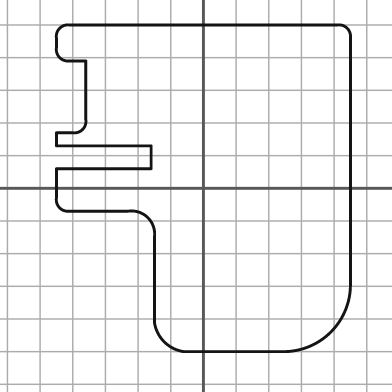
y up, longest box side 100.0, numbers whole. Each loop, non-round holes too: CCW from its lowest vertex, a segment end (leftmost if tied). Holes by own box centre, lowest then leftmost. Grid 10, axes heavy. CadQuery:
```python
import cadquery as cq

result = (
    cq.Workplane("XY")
    .moveTo(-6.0, -50.0)
    .lineTo(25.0, -50.0)
    .threePointArc((39.0, -44.0), (45.0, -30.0))
    .lineTo(45.0, 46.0)
    .threePointArc((44.0, 49.0), (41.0, 50.0))
    .lineTo(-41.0, 50.0)
    .threePointArc((-44.0, 49.0), (-45.0, 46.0))
    .lineTo(-45.0, 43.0)
    .threePointArc((-44.0, 40.0), (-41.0, 39.0))
    .lineTo(-36.0, 39.0)
    .lineTo(-36.0, 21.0)
    .threePointArc((-37.0, 18.0), (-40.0, 17.0))
    .lineTo(-45.0, 17.0)
    .lineTo(-45.0, 13.0)
    .lineTo(-16.0, 13.0)
    .lineTo(-16.0, 6.0)
    .lineTo(-45.0, 6.0)
    .lineTo(-45.0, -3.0)
    .threePointArc((-44.0, -6.0), (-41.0, -7.0))
    .lineTo(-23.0, -7.0)
    .threePointArc((-17.0, -9.0), (-15.0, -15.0))
    .lineTo(-15.0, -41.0)
    .threePointArc((-12.0, -47.0), (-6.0, -50.0))
    .close()
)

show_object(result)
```